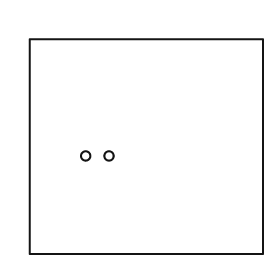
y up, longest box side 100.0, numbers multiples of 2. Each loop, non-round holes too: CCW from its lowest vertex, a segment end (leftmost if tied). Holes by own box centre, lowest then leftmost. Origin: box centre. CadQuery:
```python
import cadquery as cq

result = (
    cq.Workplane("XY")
    .moveTo(-50.0, -46.0)
    .lineTo(50.0, -46.0)
    .lineTo(50.0, 46.0)
    .lineTo(-50.0, 46.0)
    .close()
    .moveTo(-26.0, -4.0)
    .circle(2.0)
    .moveTo(-16.0, -4.0)
    .circle(2.0)
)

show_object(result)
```